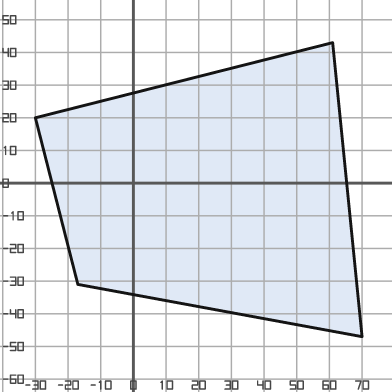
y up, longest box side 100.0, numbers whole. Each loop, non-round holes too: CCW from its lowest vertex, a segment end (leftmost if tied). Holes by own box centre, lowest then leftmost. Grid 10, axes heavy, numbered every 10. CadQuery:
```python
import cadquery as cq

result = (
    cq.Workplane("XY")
    .moveTo(70.0, -47.0)
    .lineTo(61.0, 43.0)
    .lineTo(-30.0, 20.0)
    .lineTo(-17.0, -31.0)
    .close()
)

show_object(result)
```